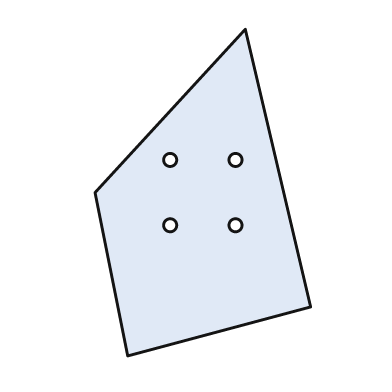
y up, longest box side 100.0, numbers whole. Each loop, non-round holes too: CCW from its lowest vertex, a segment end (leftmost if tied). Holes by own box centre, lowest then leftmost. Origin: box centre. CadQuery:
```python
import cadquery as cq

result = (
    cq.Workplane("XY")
    .moveTo(-23.0, -50.0)
    .lineTo(33.0, -35.0)
    .lineTo(13.0, 50.0)
    .lineTo(-33.0, 0.0)
    .close()
    .moveTo(-10.0, -10.0)
    .circle(2.0)
    .moveTo(10.0, -10.0)
    .circle(2.0)
    .moveTo(-10.0, 10.0)
    .circle(2.0)
    .moveTo(10.0, 10.0)
    .circle(2.0)
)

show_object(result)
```